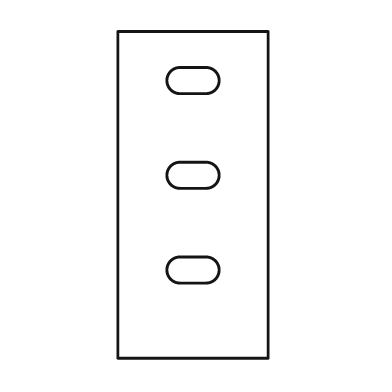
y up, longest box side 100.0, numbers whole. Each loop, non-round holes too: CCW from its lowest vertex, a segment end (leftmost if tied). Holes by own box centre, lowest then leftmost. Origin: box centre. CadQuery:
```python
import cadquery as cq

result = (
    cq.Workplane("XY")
    .moveTo(-23.0, -50.0)
    .lineTo(23.0, -50.0)
    .lineTo(23.0, 50.0)
    .lineTo(-23.0, 50.0)
    .close()
    .moveTo(-4.0, -27.0)
    .lineTo(4.0, -27.0)
    .threePointArc((8.0, -23.0), (4.0, -19.0))
    .lineTo(-4.0, -19.0)
    .threePointArc((-8.0, -23.0), (-4.0, -27.0))
    .close()
    .moveTo(-4.0, 2.0)
    .lineTo(4.0, 2.0)
    .threePointArc((8.0, 6.0), (4.0, 10.0))
    .lineTo(-4.0, 10.0)
    .threePointArc((-8.0, 6.0), (-4.0, 2.0))
    .close()
    .moveTo(-4.0, 31.0)
    .lineTo(4.0, 31.0)
    .threePointArc((8.0, 35.0), (4.0, 39.0))
    .lineTo(-4.0, 39.0)
    .threePointArc((-8.0, 35.0), (-4.0, 31.0))
    .close()
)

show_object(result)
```